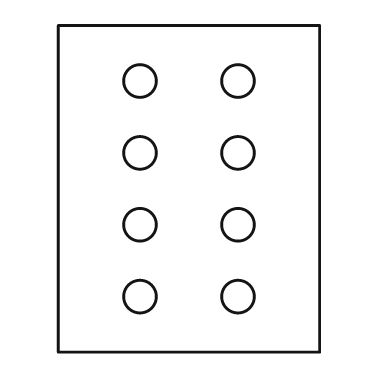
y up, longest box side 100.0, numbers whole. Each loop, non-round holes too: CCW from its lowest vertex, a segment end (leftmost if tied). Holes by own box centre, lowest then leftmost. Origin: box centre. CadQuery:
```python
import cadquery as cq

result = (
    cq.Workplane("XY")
    .moveTo(-40.0, -50.0)
    .lineTo(40.0, -50.0)
    .lineTo(40.0, 50.0)
    .lineTo(-40.0, 50.0)
    .close()
    .moveTo(-15.0, -33.0)
    .circle(5.0)
    .moveTo(15.0, -33.0)
    .circle(5.0)
    .moveTo(-15.0, -11.0)
    .circle(5.0)
    .moveTo(15.0, -11.0)
    .circle(5.0)
    .moveTo(-15.0, 11.0)
    .circle(5.0)
    .moveTo(15.0, 11.0)
    .circle(5.0)
    .moveTo(-15.0, 33.0)
    .circle(5.0)
    .moveTo(15.0, 33.0)
    .circle(5.0)
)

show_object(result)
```